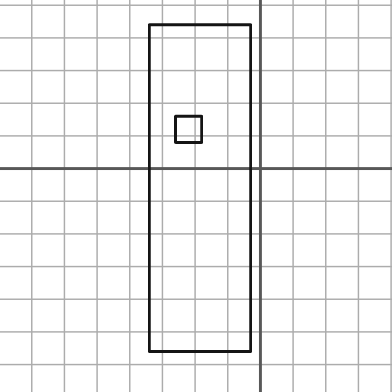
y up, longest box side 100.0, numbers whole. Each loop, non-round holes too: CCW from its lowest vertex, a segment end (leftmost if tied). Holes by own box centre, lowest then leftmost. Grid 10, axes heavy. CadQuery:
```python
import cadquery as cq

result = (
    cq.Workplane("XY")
    .moveTo(-34.0, -56.0)
    .lineTo(-3.0, -56.0)
    .lineTo(-3.0, 44.0)
    .lineTo(-34.0, 44.0)
    .close()
    .moveTo(-26.0, 8.0)
    .lineTo(-18.0, 8.0)
    .lineTo(-18.0, 16.0)
    .lineTo(-26.0, 16.0)
    .close()
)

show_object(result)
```